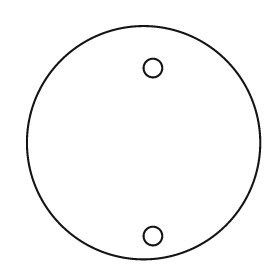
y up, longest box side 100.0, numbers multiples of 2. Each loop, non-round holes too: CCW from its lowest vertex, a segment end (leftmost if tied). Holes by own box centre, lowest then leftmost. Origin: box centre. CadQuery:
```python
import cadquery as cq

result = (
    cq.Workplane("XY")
    .moveTo(0.0, 0.0)
    .circle(50.0)
    .moveTo(4.0, -40.0)
    .circle(4.0)
    .moveTo(4.0, 32.0)
    .circle(4.0)
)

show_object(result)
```